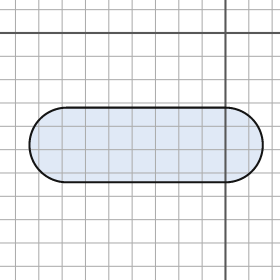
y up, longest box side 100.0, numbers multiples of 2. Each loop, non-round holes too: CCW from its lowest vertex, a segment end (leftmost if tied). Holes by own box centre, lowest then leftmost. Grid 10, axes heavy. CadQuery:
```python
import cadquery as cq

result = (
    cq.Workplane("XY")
    .moveTo(-68.0, -64.0)
    .lineTo(0.0, -64.0)
    .threePointArc((16.0, -48.0), (0.0, -32.0))
    .lineTo(-68.0, -32.0)
    .threePointArc((-84.0, -48.0), (-68.0, -64.0))
    .close()
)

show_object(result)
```